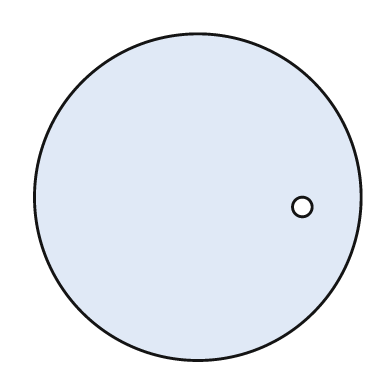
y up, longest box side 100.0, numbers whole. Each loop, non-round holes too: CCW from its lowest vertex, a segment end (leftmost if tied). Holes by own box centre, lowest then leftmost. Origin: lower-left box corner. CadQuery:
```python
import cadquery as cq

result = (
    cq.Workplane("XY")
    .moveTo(50.0, 50.0)
    .circle(50.0)
    .moveTo(82.0, 47.0)
    .circle(3.0)
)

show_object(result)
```